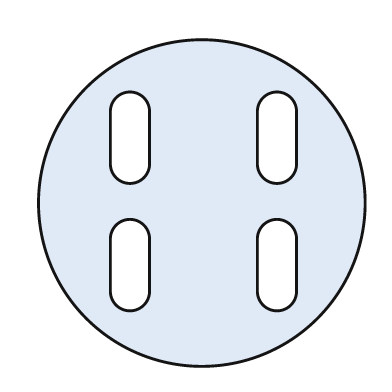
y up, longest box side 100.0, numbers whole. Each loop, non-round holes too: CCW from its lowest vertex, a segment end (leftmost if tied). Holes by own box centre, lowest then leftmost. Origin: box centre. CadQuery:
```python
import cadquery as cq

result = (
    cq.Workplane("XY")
    .moveTo(0.0, 0.0)
    .circle(50.0)
    .moveTo(-28.0, -27.0)
    .threePointArc((-22.0, -33.0), (-16.0, -27.0))
    .lineTo(-16.0, -11.0)
    .threePointArc((-22.0, -5.0), (-28.0, -11.0))
    .close()
    .moveTo(17.0, -27.0)
    .threePointArc((23.0, -33.0), (29.0, -27.0))
    .lineTo(29.0, -11.0)
    .threePointArc((23.0, -5.0), (17.0, -11.0))
    .close()
    .moveTo(-28.0, 12.0)
    .threePointArc((-22.0, 6.0), (-16.0, 12.0))
    .lineTo(-16.0, 28.0)
    .threePointArc((-22.0, 34.0), (-28.0, 28.0))
    .close()
    .moveTo(17.0, 12.0)
    .threePointArc((23.0, 6.0), (29.0, 12.0))
    .lineTo(29.0, 28.0)
    .threePointArc((23.0, 34.0), (17.0, 28.0))
    .close()
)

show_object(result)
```